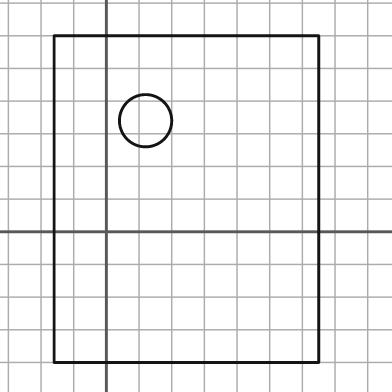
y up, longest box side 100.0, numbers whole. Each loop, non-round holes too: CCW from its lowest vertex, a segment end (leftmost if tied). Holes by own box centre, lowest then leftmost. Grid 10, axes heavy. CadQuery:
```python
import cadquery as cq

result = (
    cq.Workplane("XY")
    .moveTo(-16.0, -40.0)
    .lineTo(65.0, -40.0)
    .lineTo(65.0, 60.0)
    .lineTo(-16.0, 60.0)
    .close()
    .moveTo(12.0, 34.0)
    .circle(8.0)
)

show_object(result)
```